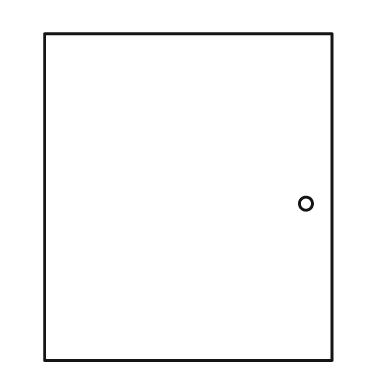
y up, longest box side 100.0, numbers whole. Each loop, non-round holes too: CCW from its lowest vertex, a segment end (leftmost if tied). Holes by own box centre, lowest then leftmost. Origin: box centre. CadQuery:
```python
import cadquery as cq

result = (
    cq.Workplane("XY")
    .moveTo(-44.0, -50.0)
    .lineTo(44.0, -50.0)
    .lineTo(44.0, 50.0)
    .lineTo(-44.0, 50.0)
    .close()
    .moveTo(36.0, -2.0)
    .circle(2.0)
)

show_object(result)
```